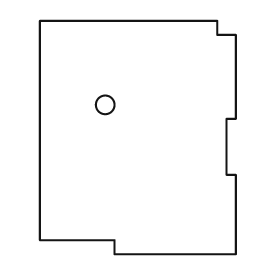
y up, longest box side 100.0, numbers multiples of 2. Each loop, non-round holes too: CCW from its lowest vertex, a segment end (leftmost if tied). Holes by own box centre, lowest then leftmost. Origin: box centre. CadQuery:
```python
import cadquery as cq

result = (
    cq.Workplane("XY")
    .moveTo(-10.0, -50.0)
    .lineTo(42.0, -50.0)
    .lineTo(42.0, -16.0)
    .lineTo(38.0, -16.0)
    .lineTo(38.0, 8.0)
    .lineTo(42.0, 8.0)
    .lineTo(42.0, 44.0)
    .lineTo(34.0, 44.0)
    .lineTo(34.0, 50.0)
    .lineTo(-42.0, 50.0)
    .lineTo(-42.0, -44.0)
    .lineTo(-10.0, -44.0)
    .close()
    .moveTo(-14.0, 14.0)
    .circle(4.0)
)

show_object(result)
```